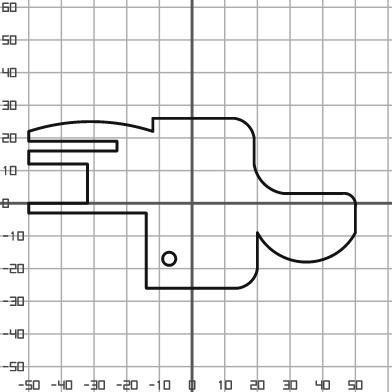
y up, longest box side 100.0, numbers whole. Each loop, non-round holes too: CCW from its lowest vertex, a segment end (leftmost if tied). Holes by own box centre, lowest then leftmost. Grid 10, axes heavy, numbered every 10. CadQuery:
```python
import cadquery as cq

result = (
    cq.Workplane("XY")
    .moveTo(-14.0, -26.0)
    .lineTo(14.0, -26.0)
    .threePointArc((18.0, -24.0), (20.0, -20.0))
    .lineTo(20.0, -9.0)
    .threePointArc((35.0, -18.0), (50.0, -9.0))
    .lineTo(50.0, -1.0)
    .threePointArc((49.0, 2.0), (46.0, 3.0))
    .lineTo(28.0, 3.0)
    .threePointArc((22.0, 6.0), (19.0, 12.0))
    .lineTo(19.0, 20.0)
    .threePointArc((17.0, 24.0), (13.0, 26.0))
    .lineTo(-12.0, 26.0)
    .lineTo(-12.0, 22.0)
    .threePointArc((-31.0, 25.0), (-50.0, 22.0))
    .lineTo(-50.0, 19.0)
    .lineTo(-23.0, 19.0)
    .lineTo(-23.0, 16.0)
    .lineTo(-50.0, 16.0)
    .lineTo(-50.0, 12.0)
    .lineTo(-32.0, 12.0)
    .lineTo(-32.0, 0.0)
    .lineTo(-50.0, 0.0)
    .lineTo(-50.0, -3.0)
    .lineTo(-14.0, -3.0)
    .close()
    .moveTo(-7.0, -17.0)
    .circle(2.0)
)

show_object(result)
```